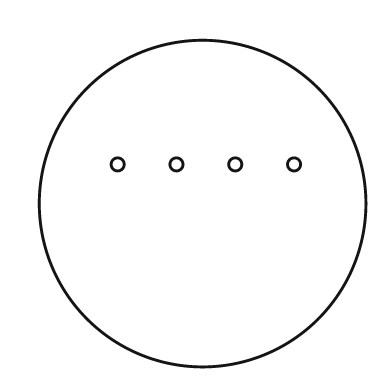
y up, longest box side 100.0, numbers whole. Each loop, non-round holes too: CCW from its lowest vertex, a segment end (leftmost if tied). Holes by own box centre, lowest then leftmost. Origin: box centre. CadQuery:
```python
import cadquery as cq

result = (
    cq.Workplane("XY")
    .moveTo(0.0, 0.0)
    .circle(50.0)
    .moveTo(-26.0, 12.0)
    .circle(2.0)
    .moveTo(-8.0, 12.0)
    .circle(2.0)
    .moveTo(10.0, 12.0)
    .circle(2.0)
    .moveTo(28.0, 12.0)
    .circle(2.0)
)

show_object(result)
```